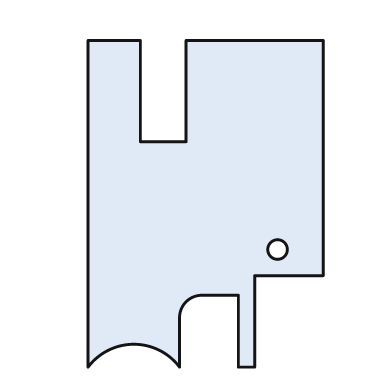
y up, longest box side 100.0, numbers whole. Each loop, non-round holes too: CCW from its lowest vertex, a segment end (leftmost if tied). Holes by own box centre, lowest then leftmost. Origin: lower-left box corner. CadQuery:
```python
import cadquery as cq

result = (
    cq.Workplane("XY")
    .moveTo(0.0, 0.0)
    .threePointArc((14.0, 7.0), (28.0, 0.0))
    .lineTo(28.0, 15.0)
    .threePointArc((30.0, 20.0), (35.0, 22.0))
    .lineTo(46.0, 22.0)
    .lineTo(46.0, 0.0)
    .lineTo(51.0, 0.0)
    .lineTo(51.0, 28.0)
    .lineTo(72.0, 28.0)
    .lineTo(72.0, 100.0)
    .lineTo(30.0, 100.0)
    .lineTo(30.0, 69.0)
    .lineTo(16.0, 69.0)
    .lineTo(16.0, 100.0)
    .lineTo(0.0, 100.0)
    .close()
    .moveTo(58.0, 36.0)
    .circle(3.0)
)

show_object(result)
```